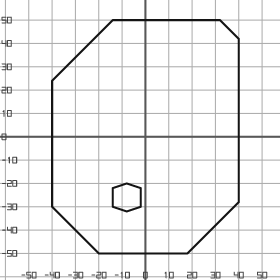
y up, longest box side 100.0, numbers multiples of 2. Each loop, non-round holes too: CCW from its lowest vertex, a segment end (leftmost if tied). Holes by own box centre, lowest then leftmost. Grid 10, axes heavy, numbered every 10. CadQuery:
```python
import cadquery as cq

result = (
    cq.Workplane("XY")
    .moveTo(-20.0, -50.0)
    .lineTo(18.0, -50.0)
    .lineTo(40.0, -28.0)
    .lineTo(40.0, 42.0)
    .lineTo(32.0, 50.0)
    .lineTo(-14.0, 50.0)
    .lineTo(-40.0, 24.0)
    .lineTo(-40.0, -30.0)
    .close()
    .moveTo(-8.0, -32.0)
    .lineTo(-2.0, -30.0)
    .lineTo(-2.0, -22.0)
    .lineTo(-8.0, -20.0)
    .lineTo(-14.0, -22.0)
    .lineTo(-14.0, -30.0)
    .close()
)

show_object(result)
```